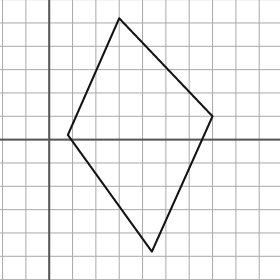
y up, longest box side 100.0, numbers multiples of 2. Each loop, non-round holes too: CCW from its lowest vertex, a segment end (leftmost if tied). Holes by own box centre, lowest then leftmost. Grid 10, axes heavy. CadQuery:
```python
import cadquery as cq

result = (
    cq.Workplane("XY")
    .moveTo(44.0, -48.0)
    .lineTo(70.0, 10.0)
    .lineTo(30.0, 52.0)
    .lineTo(8.0, 2.0)
    .close()
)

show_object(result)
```